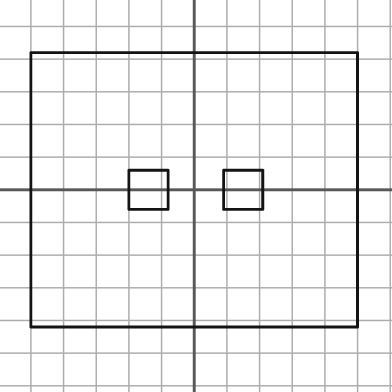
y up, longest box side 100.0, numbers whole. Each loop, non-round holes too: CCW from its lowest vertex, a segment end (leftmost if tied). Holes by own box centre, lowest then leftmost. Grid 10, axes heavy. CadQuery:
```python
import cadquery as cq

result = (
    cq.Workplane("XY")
    .moveTo(-50.0, -42.0)
    .lineTo(50.0, -42.0)
    .lineTo(50.0, 42.0)
    .lineTo(-50.0, 42.0)
    .close()
    .moveTo(-20.0, -6.0)
    .lineTo(-8.0, -6.0)
    .lineTo(-8.0, 6.0)
    .lineTo(-20.0, 6.0)
    .close()
    .moveTo(9.0, -6.0)
    .lineTo(21.0, -6.0)
    .lineTo(21.0, 6.0)
    .lineTo(9.0, 6.0)
    .close()
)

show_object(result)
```